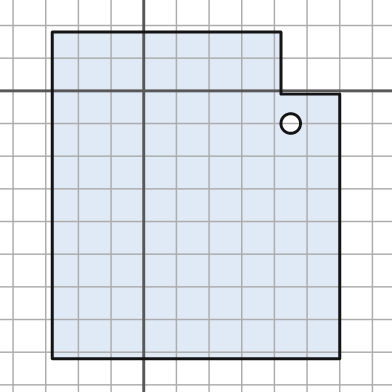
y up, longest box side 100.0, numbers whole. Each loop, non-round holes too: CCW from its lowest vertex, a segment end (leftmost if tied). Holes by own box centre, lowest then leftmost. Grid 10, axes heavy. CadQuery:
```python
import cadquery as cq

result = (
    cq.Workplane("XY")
    .moveTo(-28.0, -82.0)
    .lineTo(60.0, -82.0)
    .lineTo(60.0, -1.0)
    .lineTo(42.0, -1.0)
    .lineTo(42.0, 18.0)
    .lineTo(-28.0, 18.0)
    .close()
    .moveTo(45.0, -10.0)
    .circle(3.0)
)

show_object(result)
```